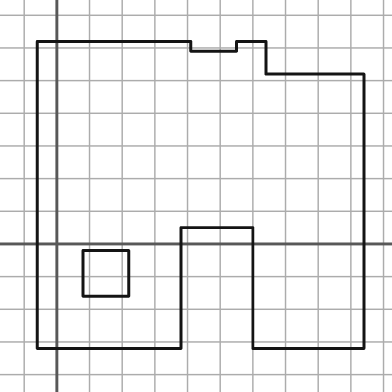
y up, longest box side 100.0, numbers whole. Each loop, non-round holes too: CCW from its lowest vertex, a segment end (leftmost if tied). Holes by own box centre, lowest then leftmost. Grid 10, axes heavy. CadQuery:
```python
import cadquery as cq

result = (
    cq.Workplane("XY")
    .moveTo(-6.0, -32.0)
    .lineTo(38.0, -32.0)
    .lineTo(38.0, 5.0)
    .lineTo(60.0, 5.0)
    .lineTo(60.0, -32.0)
    .lineTo(94.0, -32.0)
    .lineTo(94.0, 52.0)
    .lineTo(64.0, 52.0)
    .lineTo(64.0, 62.0)
    .lineTo(55.0, 62.0)
    .lineTo(55.0, 59.0)
    .lineTo(41.0, 59.0)
    .lineTo(41.0, 62.0)
    .lineTo(-6.0, 62.0)
    .close()
    .moveTo(8.0, -16.0)
    .lineTo(22.0, -16.0)
    .lineTo(22.0, -2.0)
    .lineTo(8.0, -2.0)
    .close()
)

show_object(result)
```